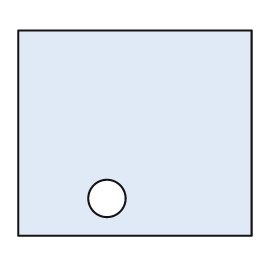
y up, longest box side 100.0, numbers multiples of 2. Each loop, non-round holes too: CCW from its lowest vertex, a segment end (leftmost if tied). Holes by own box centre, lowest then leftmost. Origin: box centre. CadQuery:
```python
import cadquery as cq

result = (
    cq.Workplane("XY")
    .moveTo(-50.0, -44.0)
    .lineTo(50.0, -44.0)
    .lineTo(50.0, 44.0)
    .lineTo(-50.0, 44.0)
    .close()
    .moveTo(-12.0, -28.0)
    .circle(8.0)
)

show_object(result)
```